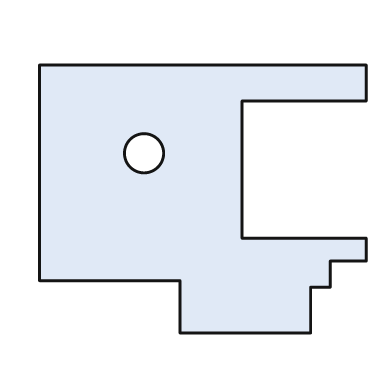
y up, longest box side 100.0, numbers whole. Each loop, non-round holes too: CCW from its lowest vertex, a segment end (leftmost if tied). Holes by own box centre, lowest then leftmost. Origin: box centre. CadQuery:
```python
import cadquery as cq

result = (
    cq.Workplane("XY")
    .moveTo(-7.0, -41.0)
    .lineTo(33.0, -41.0)
    .lineTo(33.0, -27.0)
    .lineTo(39.0, -27.0)
    .lineTo(39.0, -19.0)
    .lineTo(50.0, -19.0)
    .lineTo(50.0, -12.0)
    .lineTo(12.0, -12.0)
    .lineTo(12.0, 30.0)
    .lineTo(50.0, 30.0)
    .lineTo(50.0, 41.0)
    .lineTo(-50.0, 41.0)
    .lineTo(-50.0, -25.0)
    .lineTo(-7.0, -25.0)
    .close()
    .moveTo(-18.0, 14.0)
    .circle(6.0)
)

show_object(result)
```